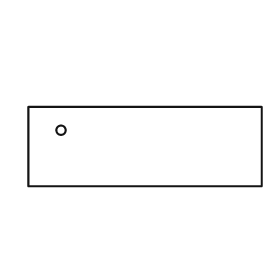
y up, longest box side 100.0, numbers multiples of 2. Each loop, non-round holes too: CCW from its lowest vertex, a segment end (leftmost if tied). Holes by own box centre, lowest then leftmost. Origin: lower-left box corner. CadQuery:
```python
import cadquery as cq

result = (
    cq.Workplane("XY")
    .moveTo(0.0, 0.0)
    .lineTo(100.0, 0.0)
    .lineTo(100.0, 34.0)
    .lineTo(0.0, 34.0)
    .close()
    .moveTo(14.0, 24.0)
    .circle(2.0)
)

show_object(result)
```